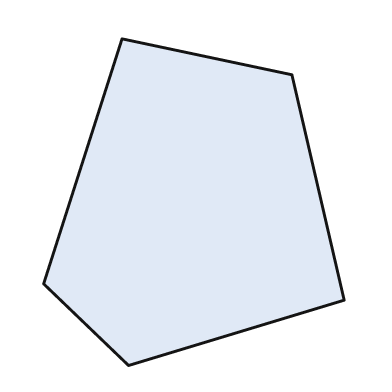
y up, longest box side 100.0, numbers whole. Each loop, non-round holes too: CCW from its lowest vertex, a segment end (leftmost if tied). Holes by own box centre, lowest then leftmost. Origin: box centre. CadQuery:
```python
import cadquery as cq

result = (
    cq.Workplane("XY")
    .moveTo(-20.0, -50.0)
    .lineTo(46.0, -30.0)
    .lineTo(30.0, 39.0)
    .lineTo(-22.0, 50.0)
    .lineTo(-46.0, -25.0)
    .close()
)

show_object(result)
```